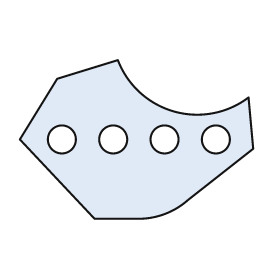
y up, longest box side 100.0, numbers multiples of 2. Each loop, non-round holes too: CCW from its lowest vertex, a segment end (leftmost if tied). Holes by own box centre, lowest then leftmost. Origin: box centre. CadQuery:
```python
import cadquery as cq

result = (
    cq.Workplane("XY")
    .moveTo(-18.0, -34.0)
    .lineTo(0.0, -34.0)
    .threePointArc((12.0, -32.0), (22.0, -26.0))
    .lineTo(50.0, -4.0)
    .lineTo(48.0, 18.0)
    .threePointArc((16.0, 12.0), (-8.0, 34.0))
    .lineTo(-34.0, 26.0)
    .lineTo(-50.0, 0.0)
    .close()
    .moveTo(-32.0, 0.0)
    .circle(6.0)
    .moveTo(-10.0, 0.0)
    .circle(6.0)
    .moveTo(12.0, 0.0)
    .circle(6.0)
    .moveTo(34.0, 0.0)
    .circle(6.0)
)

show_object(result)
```